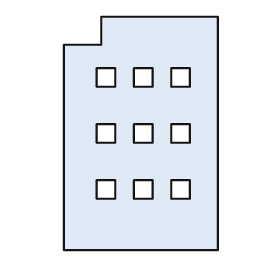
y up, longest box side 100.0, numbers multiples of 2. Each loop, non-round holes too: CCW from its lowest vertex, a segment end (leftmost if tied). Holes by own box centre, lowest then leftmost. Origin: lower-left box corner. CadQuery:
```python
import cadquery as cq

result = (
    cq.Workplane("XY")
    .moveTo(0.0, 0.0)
    .lineTo(66.0, 0.0)
    .lineTo(66.0, 100.0)
    .lineTo(16.0, 100.0)
    .lineTo(16.0, 88.0)
    .lineTo(0.0, 88.0)
    .close()
    .moveTo(14.0, 22.0)
    .lineTo(22.0, 22.0)
    .lineTo(22.0, 30.0)
    .lineTo(14.0, 30.0)
    .close()
    .moveTo(30.0, 22.0)
    .lineTo(38.0, 22.0)
    .lineTo(38.0, 30.0)
    .lineTo(30.0, 30.0)
    .close()
    .moveTo(46.0, 22.0)
    .lineTo(54.0, 22.0)
    .lineTo(54.0, 30.0)
    .lineTo(46.0, 30.0)
    .close()
    .moveTo(14.0, 46.0)
    .lineTo(22.0, 46.0)
    .lineTo(22.0, 54.0)
    .lineTo(14.0, 54.0)
    .close()
    .moveTo(30.0, 46.0)
    .lineTo(38.0, 46.0)
    .lineTo(38.0, 54.0)
    .lineTo(30.0, 54.0)
    .close()
    .moveTo(46.0, 46.0)
    .lineTo(54.0, 46.0)
    .lineTo(54.0, 54.0)
    .lineTo(46.0, 54.0)
    .close()
    .moveTo(14.0, 70.0)
    .lineTo(22.0, 70.0)
    .lineTo(22.0, 78.0)
    .lineTo(14.0, 78.0)
    .close()
    .moveTo(30.0, 70.0)
    .lineTo(38.0, 70.0)
    .lineTo(38.0, 78.0)
    .lineTo(30.0, 78.0)
    .close()
    .moveTo(46.0, 70.0)
    .lineTo(54.0, 70.0)
    .lineTo(54.0, 78.0)
    .lineTo(46.0, 78.0)
    .close()
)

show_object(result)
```